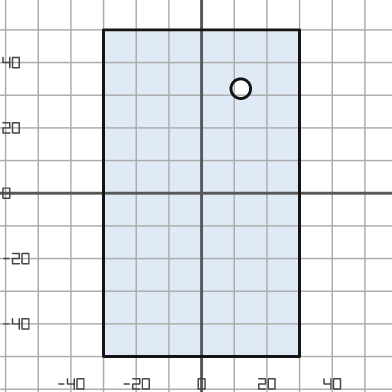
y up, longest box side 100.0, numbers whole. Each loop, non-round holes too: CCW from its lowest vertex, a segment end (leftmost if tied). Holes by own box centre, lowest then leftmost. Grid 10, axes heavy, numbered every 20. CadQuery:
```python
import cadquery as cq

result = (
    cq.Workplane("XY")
    .moveTo(-30.0, -50.0)
    .lineTo(30.0, -50.0)
    .lineTo(30.0, 50.0)
    .lineTo(-30.0, 50.0)
    .close()
    .moveTo(12.0, 32.0)
    .circle(3.0)
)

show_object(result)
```